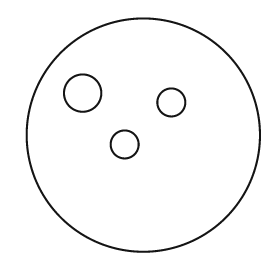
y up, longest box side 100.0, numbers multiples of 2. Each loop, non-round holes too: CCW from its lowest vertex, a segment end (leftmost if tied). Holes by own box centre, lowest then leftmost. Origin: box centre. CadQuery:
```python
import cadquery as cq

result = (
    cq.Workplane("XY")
    .moveTo(0.0, 0.0)
    .circle(50.0)
    .moveTo(-8.0, -4.0)
    .circle(6.0)
    .moveTo(12.0, 14.0)
    .circle(6.0)
    .moveTo(-26.0, 18.0)
    .circle(8.0)
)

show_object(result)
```